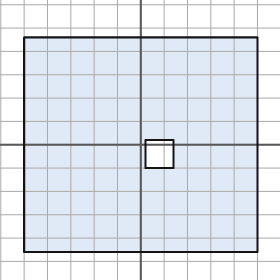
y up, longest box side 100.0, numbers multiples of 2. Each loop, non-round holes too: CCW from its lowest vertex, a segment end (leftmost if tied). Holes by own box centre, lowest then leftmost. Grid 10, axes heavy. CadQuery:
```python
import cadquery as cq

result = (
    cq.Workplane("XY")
    .moveTo(-50.0, -46.0)
    .lineTo(50.0, -46.0)
    .lineTo(50.0, 46.0)
    .lineTo(-50.0, 46.0)
    .close()
    .moveTo(2.0, -10.0)
    .lineTo(14.0, -10.0)
    .lineTo(14.0, 2.0)
    .lineTo(2.0, 2.0)
    .close()
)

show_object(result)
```